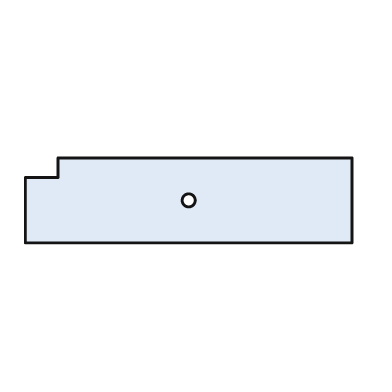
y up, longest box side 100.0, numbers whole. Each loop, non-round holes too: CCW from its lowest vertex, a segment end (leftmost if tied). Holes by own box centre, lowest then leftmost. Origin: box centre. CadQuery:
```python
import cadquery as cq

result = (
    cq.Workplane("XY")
    .moveTo(-50.0, -13.0)
    .lineTo(50.0, -13.0)
    .lineTo(50.0, 13.0)
    .lineTo(-40.0, 13.0)
    .lineTo(-40.0, 7.0)
    .lineTo(-50.0, 7.0)
    .close()
    .moveTo(0.0, 0.0)
    .circle(2.0)
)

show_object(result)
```